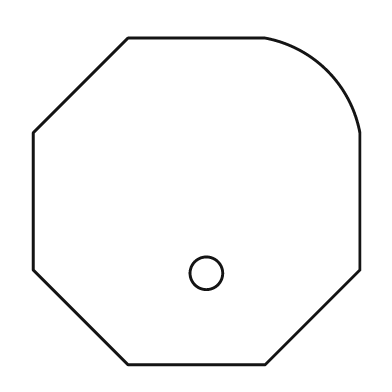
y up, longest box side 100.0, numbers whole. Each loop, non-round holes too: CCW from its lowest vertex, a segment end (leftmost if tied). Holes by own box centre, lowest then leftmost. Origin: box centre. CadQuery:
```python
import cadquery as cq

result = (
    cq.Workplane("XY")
    .moveTo(-21.0, -50.0)
    .lineTo(21.0, -50.0)
    .lineTo(50.0, -21.0)
    .lineTo(50.0, 21.0)
    .threePointArc((40.0, 40.0), (21.0, 50.0))
    .lineTo(-21.0, 50.0)
    .lineTo(-50.0, 21.0)
    .lineTo(-50.0, -21.0)
    .close()
    .moveTo(3.0, -22.0)
    .circle(5.0)
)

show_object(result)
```